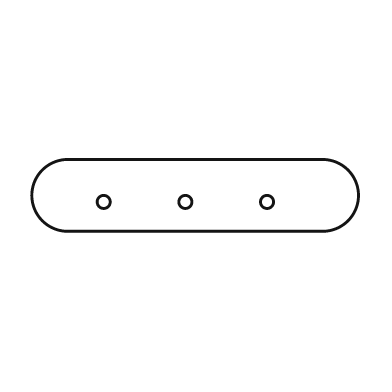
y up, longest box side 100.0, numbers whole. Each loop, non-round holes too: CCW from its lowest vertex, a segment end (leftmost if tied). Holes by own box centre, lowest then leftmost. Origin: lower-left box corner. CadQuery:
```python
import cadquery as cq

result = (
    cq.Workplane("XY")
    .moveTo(11.0, 0.0)
    .lineTo(89.0, 0.0)
    .threePointArc((100.0, 11.0), (89.0, 22.0))
    .lineTo(11.0, 22.0)
    .threePointArc((0.0, 11.0), (11.0, 0.0))
    .close()
    .moveTo(22.0, 9.0)
    .circle(2.0)
    .moveTo(47.0, 9.0)
    .circle(2.0)
    .moveTo(72.0, 9.0)
    .circle(2.0)
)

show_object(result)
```